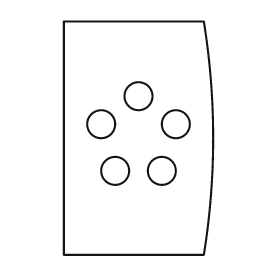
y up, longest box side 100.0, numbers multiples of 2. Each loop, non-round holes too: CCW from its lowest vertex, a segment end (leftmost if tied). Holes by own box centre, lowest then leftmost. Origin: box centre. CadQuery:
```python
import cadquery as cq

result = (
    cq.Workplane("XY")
    .moveTo(-32.0, -50.0)
    .lineTo(28.0, -50.0)
    .threePointArc((32.0, 0.0), (28.0, 50.0))
    .lineTo(-32.0, 50.0)
    .close()
    .moveTo(-10.0, -14.0)
    .circle(6.0)
    .moveTo(10.0, -14.0)
    .circle(6.0)
    .moveTo(-16.0, 6.0)
    .circle(6.0)
    .moveTo(16.0, 6.0)
    .circle(6.0)
    .moveTo(0.0, 18.0)
    .circle(6.0)
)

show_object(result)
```